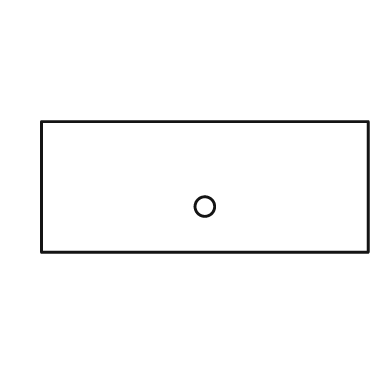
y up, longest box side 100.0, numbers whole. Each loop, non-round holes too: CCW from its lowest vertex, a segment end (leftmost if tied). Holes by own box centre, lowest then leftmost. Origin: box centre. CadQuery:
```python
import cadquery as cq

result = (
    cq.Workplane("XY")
    .moveTo(-50.0, -20.0)
    .lineTo(50.0, -20.0)
    .lineTo(50.0, 20.0)
    .lineTo(-50.0, 20.0)
    .close()
    .moveTo(0.0, -6.0)
    .circle(3.0)
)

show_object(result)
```